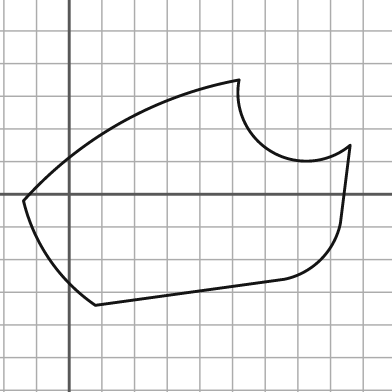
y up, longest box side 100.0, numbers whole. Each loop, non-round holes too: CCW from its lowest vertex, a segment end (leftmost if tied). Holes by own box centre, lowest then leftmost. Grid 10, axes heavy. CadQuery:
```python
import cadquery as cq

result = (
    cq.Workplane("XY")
    .moveTo(8.0, -34.0)
    .lineTo(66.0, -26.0)
    .threePointArc((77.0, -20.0), (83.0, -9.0))
    .lineTo(86.0, 15.0)
    .threePointArc((62.0, 13.0), (52.0, 35.0))
    .threePointArc((16.0, 22.0), (-14.0, -2.0))
    .threePointArc((-6.0, -20.0), (8.0, -34.0))
    .close()
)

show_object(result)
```